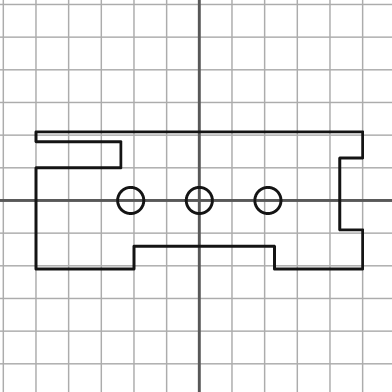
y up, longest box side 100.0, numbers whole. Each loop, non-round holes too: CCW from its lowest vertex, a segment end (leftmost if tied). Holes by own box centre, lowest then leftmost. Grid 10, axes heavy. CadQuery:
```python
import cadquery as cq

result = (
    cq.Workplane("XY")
    .moveTo(-50.0, -21.0)
    .lineTo(-20.0, -21.0)
    .lineTo(-20.0, -14.0)
    .lineTo(23.0, -14.0)
    .lineTo(23.0, -21.0)
    .lineTo(50.0, -21.0)
    .lineTo(50.0, -9.0)
    .lineTo(43.0, -9.0)
    .lineTo(43.0, 13.0)
    .lineTo(50.0, 13.0)
    .lineTo(50.0, 21.0)
    .lineTo(-50.0, 21.0)
    .lineTo(-50.0, 18.0)
    .lineTo(-24.0, 18.0)
    .lineTo(-24.0, 10.0)
    .lineTo(-50.0, 10.0)
    .close()
    .moveTo(-21.0, 0.0)
    .circle(4.0)
    .moveTo(0.0, 0.0)
    .circle(4.0)
    .moveTo(21.0, 0.0)
    .circle(4.0)
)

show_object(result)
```